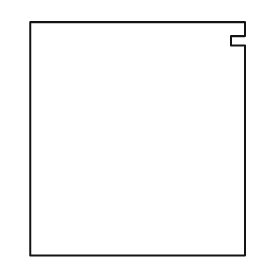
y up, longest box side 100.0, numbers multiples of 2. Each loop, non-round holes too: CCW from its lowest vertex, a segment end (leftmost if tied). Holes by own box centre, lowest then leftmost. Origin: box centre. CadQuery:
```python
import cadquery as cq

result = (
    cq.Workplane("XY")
    .moveTo(-46.0, -50.0)
    .lineTo(46.0, -50.0)
    .lineTo(46.0, 40.0)
    .lineTo(40.0, 40.0)
    .lineTo(40.0, 44.0)
    .lineTo(46.0, 44.0)
    .lineTo(46.0, 50.0)
    .lineTo(-46.0, 50.0)
    .close()
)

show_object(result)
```